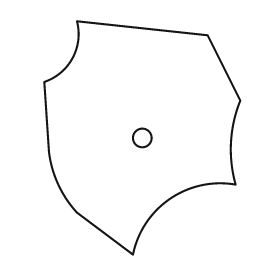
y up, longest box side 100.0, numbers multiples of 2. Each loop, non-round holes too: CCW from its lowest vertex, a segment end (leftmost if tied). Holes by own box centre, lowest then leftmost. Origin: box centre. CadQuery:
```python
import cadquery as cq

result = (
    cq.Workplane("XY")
    .moveTo(-4.0, -50.0)
    .threePointArc((12.0, -26.0), (40.0, -20.0))
    .threePointArc((38.0, -2.0), (42.0, 16.0))
    .lineTo(28.0, 44.0)
    .lineTo(-28.0, 50.0)
    .threePointArc((-30.0, 34.0), (-42.0, 24.0))
    .lineTo(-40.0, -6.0)
    .threePointArc((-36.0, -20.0), (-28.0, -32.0))
    .close()
    .moveTo(0.0, 0.0)
    .circle(4.0)
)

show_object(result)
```